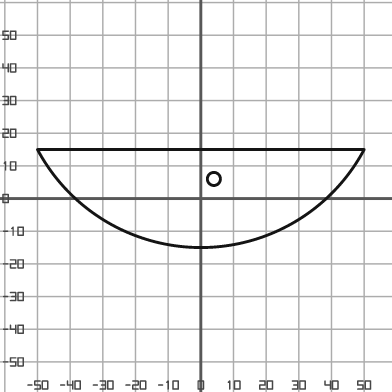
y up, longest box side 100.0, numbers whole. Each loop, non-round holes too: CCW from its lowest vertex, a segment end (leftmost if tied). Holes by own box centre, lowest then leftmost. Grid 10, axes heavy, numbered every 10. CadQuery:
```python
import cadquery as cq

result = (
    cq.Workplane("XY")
    .moveTo(-50.0, 15.0)
    .threePointArc((0.0, -15.0), (50.0, 15.0))
    .close()
    .moveTo(4.0, 6.0)
    .circle(2.0)
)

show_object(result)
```